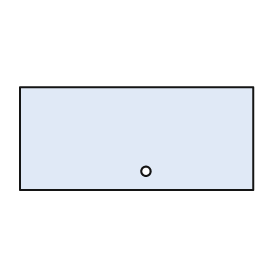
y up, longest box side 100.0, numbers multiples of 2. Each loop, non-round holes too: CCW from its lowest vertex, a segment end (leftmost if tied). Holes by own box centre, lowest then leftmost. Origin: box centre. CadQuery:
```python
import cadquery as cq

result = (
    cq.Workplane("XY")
    .moveTo(-50.0, -22.0)
    .lineTo(50.0, -22.0)
    .lineTo(50.0, 22.0)
    .lineTo(-50.0, 22.0)
    .close()
    .moveTo(4.0, -14.0)
    .circle(2.0)
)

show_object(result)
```